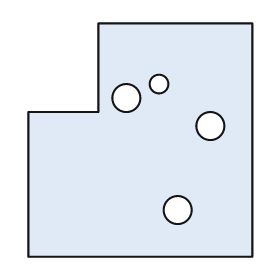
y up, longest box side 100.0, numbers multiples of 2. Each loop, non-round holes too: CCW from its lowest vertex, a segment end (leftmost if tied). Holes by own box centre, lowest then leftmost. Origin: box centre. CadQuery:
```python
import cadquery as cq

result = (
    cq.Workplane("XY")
    .moveTo(-48.0, -50.0)
    .lineTo(48.0, -50.0)
    .lineTo(48.0, 50.0)
    .lineTo(-18.0, 50.0)
    .lineTo(-18.0, 12.0)
    .lineTo(-48.0, 12.0)
    .close()
    .moveTo(16.0, -30.0)
    .circle(6.0)
    .moveTo(30.0, 6.0)
    .circle(6.0)
    .moveTo(-6.0, 18.0)
    .circle(6.0)
    .moveTo(8.0, 24.0)
    .circle(4.0)
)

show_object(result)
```